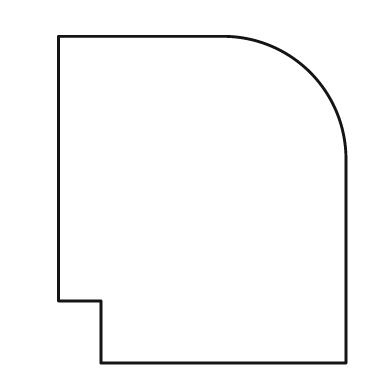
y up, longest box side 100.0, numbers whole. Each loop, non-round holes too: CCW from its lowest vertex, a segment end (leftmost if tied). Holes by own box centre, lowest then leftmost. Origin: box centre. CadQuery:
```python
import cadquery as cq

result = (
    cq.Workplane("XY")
    .moveTo(-31.0, -50.0)
    .lineTo(44.0, -50.0)
    .lineTo(44.0, 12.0)
    .threePointArc((33.0, 39.0), (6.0, 50.0))
    .lineTo(-44.0, 50.0)
    .lineTo(-44.0, -31.0)
    .lineTo(-31.0, -31.0)
    .close()
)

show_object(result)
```